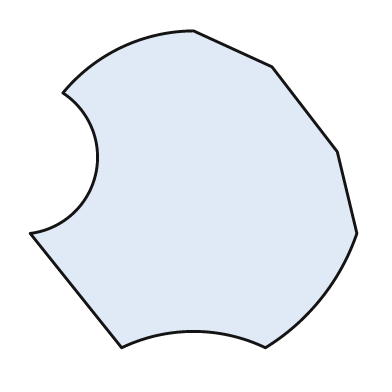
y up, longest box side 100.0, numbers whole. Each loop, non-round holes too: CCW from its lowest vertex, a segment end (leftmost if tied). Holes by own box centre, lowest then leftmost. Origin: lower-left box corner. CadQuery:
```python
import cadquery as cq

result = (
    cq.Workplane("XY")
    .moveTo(28.0, 0.0)
    .threePointArc((50.0, 5.0), (72.0, 0.0))
    .threePointArc((89.0, 15.0), (100.0, 35.0))
    .lineTo(94.0, 60.0)
    .lineTo(74.0, 86.0)
    .lineTo(50.0, 97.0)
    .threePointArc((28.0, 92.0), (10.0, 78.0))
    .threePointArc((20.0, 53.0), (0.0, 35.0))
    .close()
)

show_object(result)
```